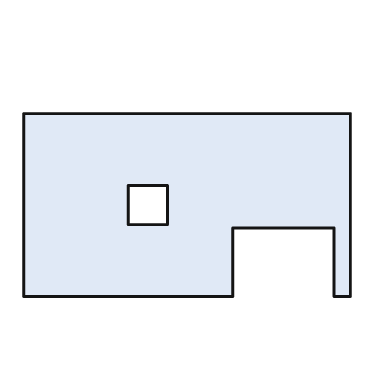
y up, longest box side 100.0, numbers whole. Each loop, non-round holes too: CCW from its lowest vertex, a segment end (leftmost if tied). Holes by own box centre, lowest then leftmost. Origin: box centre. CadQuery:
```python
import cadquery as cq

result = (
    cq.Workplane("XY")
    .moveTo(-50.0, -28.0)
    .lineTo(14.0, -28.0)
    .lineTo(14.0, -7.0)
    .lineTo(45.0, -7.0)
    .lineTo(45.0, -28.0)
    .lineTo(50.0, -28.0)
    .lineTo(50.0, 28.0)
    .lineTo(-50.0, 28.0)
    .close()
    .moveTo(-18.0, -6.0)
    .lineTo(-6.0, -6.0)
    .lineTo(-6.0, 6.0)
    .lineTo(-18.0, 6.0)
    .close()
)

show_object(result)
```